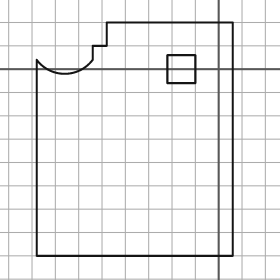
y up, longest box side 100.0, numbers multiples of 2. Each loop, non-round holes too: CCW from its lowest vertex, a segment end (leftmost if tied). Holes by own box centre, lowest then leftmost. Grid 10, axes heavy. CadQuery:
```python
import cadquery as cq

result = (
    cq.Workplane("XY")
    .moveTo(-78.0, -80.0)
    .lineTo(6.0, -80.0)
    .lineTo(6.0, 20.0)
    .lineTo(-48.0, 20.0)
    .lineTo(-48.0, 10.0)
    .lineTo(-54.0, 10.0)
    .lineTo(-54.0, 4.0)
    .threePointArc((-66.0, -2.0), (-78.0, 4.0))
    .close()
    .moveTo(-22.0, -6.0)
    .lineTo(-10.0, -6.0)
    .lineTo(-10.0, 6.0)
    .lineTo(-22.0, 6.0)
    .close()
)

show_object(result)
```